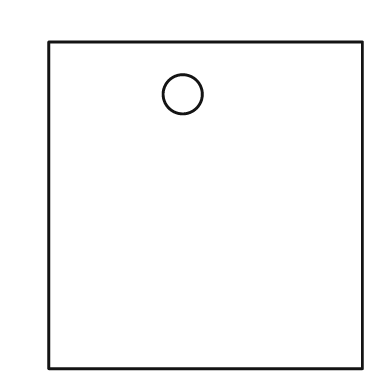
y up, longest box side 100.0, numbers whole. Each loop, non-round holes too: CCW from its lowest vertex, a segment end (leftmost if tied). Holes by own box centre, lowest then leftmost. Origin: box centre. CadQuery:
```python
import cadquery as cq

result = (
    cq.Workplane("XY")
    .moveTo(-48.0, -50.0)
    .lineTo(48.0, -50.0)
    .lineTo(48.0, 50.0)
    .lineTo(-48.0, 50.0)
    .close()
    .moveTo(-7.0, 34.0)
    .circle(6.0)
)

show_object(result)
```